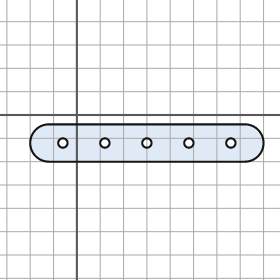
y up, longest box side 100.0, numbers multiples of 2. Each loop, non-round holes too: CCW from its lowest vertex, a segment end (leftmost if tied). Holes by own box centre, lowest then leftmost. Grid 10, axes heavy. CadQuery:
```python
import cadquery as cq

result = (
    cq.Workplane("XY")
    .moveTo(-12.0, -20.0)
    .lineTo(72.0, -20.0)
    .threePointArc((80.0, -12.0), (72.0, -4.0))
    .lineTo(-12.0, -4.0)
    .threePointArc((-20.0, -12.0), (-12.0, -20.0))
    .close()
    .moveTo(-6.0, -12.0)
    .circle(2.0)
    .moveTo(12.0, -12.0)
    .circle(2.0)
    .moveTo(30.0, -12.0)
    .circle(2.0)
    .moveTo(48.0, -12.0)
    .circle(2.0)
    .moveTo(66.0, -12.0)
    .circle(2.0)
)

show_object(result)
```